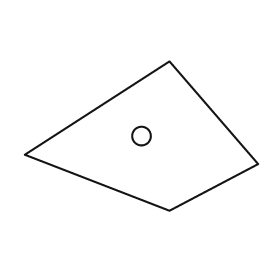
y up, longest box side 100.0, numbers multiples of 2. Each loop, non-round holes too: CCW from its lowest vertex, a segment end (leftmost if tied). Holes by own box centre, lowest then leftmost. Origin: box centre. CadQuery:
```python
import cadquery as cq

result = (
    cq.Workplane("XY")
    .moveTo(12.0, -32.0)
    .lineTo(50.0, -12.0)
    .lineTo(12.0, 32.0)
    .lineTo(-50.0, -8.0)
    .close()
    .moveTo(0.0, 0.0)
    .circle(4.0)
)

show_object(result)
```